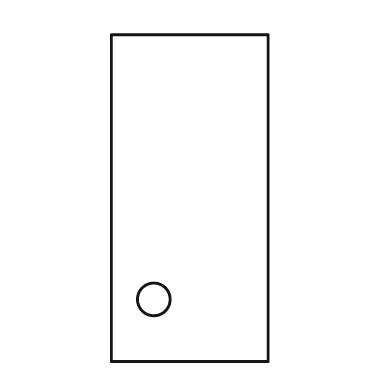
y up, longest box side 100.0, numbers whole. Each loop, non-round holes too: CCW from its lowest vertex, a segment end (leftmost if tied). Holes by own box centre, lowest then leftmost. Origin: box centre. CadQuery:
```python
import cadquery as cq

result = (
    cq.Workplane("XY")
    .moveTo(-24.0, -50.0)
    .lineTo(24.0, -50.0)
    .lineTo(24.0, 50.0)
    .lineTo(-24.0, 50.0)
    .close()
    .moveTo(-11.0, -31.0)
    .circle(5.0)
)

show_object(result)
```